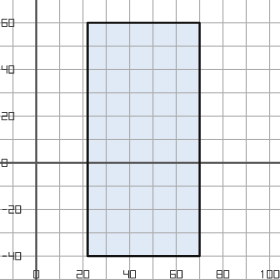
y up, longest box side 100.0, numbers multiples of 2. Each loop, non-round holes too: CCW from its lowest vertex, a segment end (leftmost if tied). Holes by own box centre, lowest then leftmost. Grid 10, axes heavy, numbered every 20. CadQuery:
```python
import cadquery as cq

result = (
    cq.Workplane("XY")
    .moveTo(22.0, -40.0)
    .lineTo(70.0, -40.0)
    .lineTo(70.0, 60.0)
    .lineTo(22.0, 60.0)
    .close()
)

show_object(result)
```